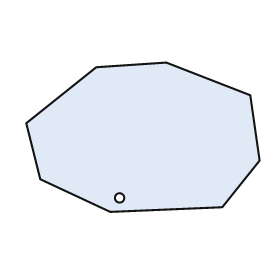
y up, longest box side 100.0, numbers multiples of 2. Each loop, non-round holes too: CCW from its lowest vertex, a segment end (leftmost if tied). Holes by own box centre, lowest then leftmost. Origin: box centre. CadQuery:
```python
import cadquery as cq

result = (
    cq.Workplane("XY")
    .moveTo(-14.0, -32.0)
    .lineTo(34.0, -30.0)
    .lineTo(50.0, -10.0)
    .lineTo(46.0, 18.0)
    .lineTo(10.0, 32.0)
    .lineTo(-20.0, 30.0)
    .lineTo(-50.0, 6.0)
    .lineTo(-44.0, -18.0)
    .close()
    .moveTo(-10.0, -26.0)
    .circle(2.0)
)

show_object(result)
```